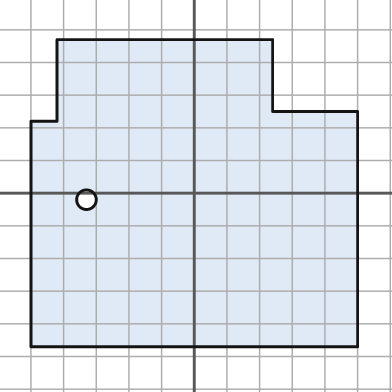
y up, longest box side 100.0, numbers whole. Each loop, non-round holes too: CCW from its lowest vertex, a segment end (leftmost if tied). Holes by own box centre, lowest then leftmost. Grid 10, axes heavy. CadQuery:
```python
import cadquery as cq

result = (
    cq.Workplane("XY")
    .moveTo(-50.0, -47.0)
    .lineTo(50.0, -47.0)
    .lineTo(50.0, 25.0)
    .lineTo(24.0, 25.0)
    .lineTo(24.0, 47.0)
    .lineTo(-42.0, 47.0)
    .lineTo(-42.0, 22.0)
    .lineTo(-50.0, 22.0)
    .close()
    .moveTo(-33.0, -2.0)
    .circle(3.0)
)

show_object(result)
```